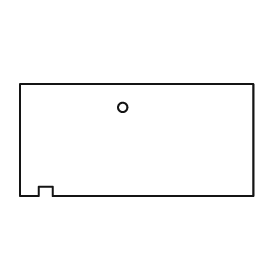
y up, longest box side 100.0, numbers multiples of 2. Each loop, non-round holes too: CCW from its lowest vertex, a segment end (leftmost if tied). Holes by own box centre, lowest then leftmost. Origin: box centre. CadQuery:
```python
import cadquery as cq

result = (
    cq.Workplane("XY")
    .moveTo(-50.0, -24.0)
    .lineTo(-42.0, -24.0)
    .lineTo(-42.0, -20.0)
    .lineTo(-36.0, -20.0)
    .lineTo(-36.0, -24.0)
    .lineTo(50.0, -24.0)
    .lineTo(50.0, 24.0)
    .lineTo(-50.0, 24.0)
    .close()
    .moveTo(-6.0, 14.0)
    .circle(2.0)
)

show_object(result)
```